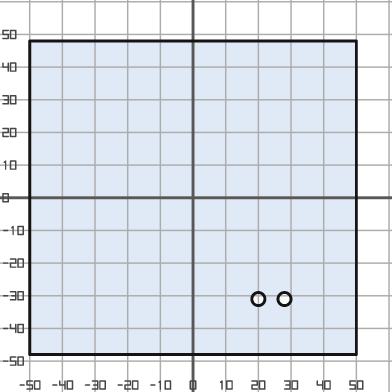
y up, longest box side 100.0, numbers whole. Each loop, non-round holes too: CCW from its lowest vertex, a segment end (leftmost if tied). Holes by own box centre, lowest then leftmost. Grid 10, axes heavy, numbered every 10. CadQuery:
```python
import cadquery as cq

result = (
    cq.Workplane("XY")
    .moveTo(-50.0, -48.0)
    .lineTo(50.0, -48.0)
    .lineTo(50.0, 48.0)
    .lineTo(-50.0, 48.0)
    .close()
    .moveTo(20.0, -31.0)
    .circle(2.0)
    .moveTo(28.0, -31.0)
    .circle(2.0)
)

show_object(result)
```